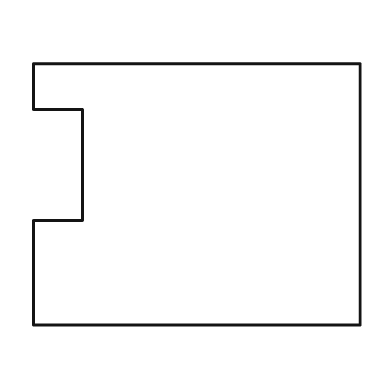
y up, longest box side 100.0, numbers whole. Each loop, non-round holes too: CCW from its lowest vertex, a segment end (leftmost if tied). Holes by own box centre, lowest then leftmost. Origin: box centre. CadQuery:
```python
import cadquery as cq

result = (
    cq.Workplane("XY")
    .moveTo(-50.0, -40.0)
    .lineTo(50.0, -40.0)
    .lineTo(50.0, 40.0)
    .lineTo(-50.0, 40.0)
    .lineTo(-50.0, 26.0)
    .lineTo(-35.0, 26.0)
    .lineTo(-35.0, -8.0)
    .lineTo(-50.0, -8.0)
    .close()
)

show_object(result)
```